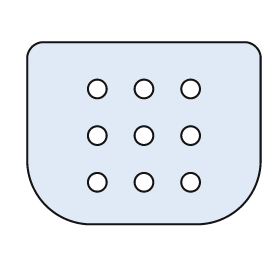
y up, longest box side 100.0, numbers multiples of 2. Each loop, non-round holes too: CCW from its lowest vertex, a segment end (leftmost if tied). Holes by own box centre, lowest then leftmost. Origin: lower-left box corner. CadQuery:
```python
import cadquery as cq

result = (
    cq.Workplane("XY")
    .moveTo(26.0, 0.0)
    .lineTo(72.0, 0.0)
    .threePointArc((92.0, 8.0), (100.0, 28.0))
    .lineTo(100.0, 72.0)
    .threePointArc((98.0, 76.0), (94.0, 78.0))
    .lineTo(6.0, 78.0)
    .threePointArc((2.0, 76.0), (0.0, 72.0))
    .lineTo(0.0, 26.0)
    .threePointArc((8.0, 8.0), (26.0, 0.0))
    .close()
    .moveTo(30.0, 18.0)
    .circle(4.0)
    .moveTo(50.0, 18.0)
    .circle(4.0)
    .moveTo(70.0, 18.0)
    .circle(4.0)
    .moveTo(30.0, 38.0)
    .circle(4.0)
    .moveTo(50.0, 38.0)
    .circle(4.0)
    .moveTo(70.0, 38.0)
    .circle(4.0)
    .moveTo(30.0, 58.0)
    .circle(4.0)
    .moveTo(50.0, 58.0)
    .circle(4.0)
    .moveTo(70.0, 58.0)
    .circle(4.0)
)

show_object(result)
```